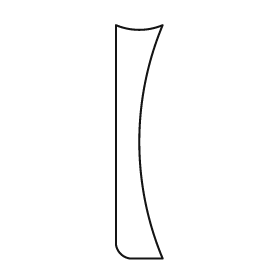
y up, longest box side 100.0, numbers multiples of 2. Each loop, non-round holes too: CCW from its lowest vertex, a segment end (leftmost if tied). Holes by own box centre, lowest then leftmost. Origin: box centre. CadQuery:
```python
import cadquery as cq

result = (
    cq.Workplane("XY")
    .moveTo(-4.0, -50.0)
    .lineTo(10.0, -50.0)
    .threePointArc((0.0, 0.0), (10.0, 50.0))
    .threePointArc((0.0, 48.0), (-10.0, 50.0))
    .lineTo(-10.0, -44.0)
    .threePointArc((-8.0, -48.0), (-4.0, -50.0))
    .close()
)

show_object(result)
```